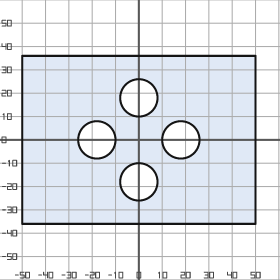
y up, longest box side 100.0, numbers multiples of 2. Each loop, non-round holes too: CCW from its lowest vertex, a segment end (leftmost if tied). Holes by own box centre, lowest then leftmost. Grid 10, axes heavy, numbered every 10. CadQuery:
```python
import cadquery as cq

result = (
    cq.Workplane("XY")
    .moveTo(-50.0, -36.0)
    .lineTo(50.0, -36.0)
    .lineTo(50.0, 36.0)
    .lineTo(-50.0, 36.0)
    .close()
    .moveTo(0.0, -18.0)
    .circle(8.0)
    .moveTo(-18.0, 0.0)
    .circle(8.0)
    .moveTo(18.0, 0.0)
    .circle(8.0)
    .moveTo(0.0, 18.0)
    .circle(8.0)
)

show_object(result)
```